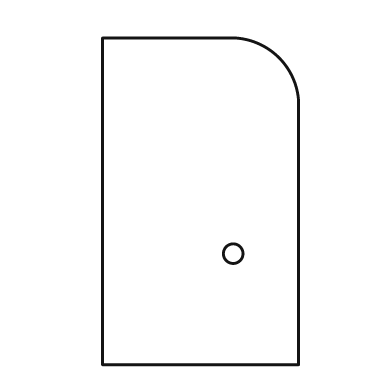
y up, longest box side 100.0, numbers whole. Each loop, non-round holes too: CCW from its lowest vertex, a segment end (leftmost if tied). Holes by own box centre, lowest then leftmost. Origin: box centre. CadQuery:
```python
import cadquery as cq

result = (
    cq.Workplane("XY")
    .moveTo(-30.0, -50.0)
    .lineTo(30.0, -50.0)
    .lineTo(30.0, 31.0)
    .threePointArc((24.0, 44.0), (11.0, 50.0))
    .lineTo(-30.0, 50.0)
    .close()
    .moveTo(10.0, -16.0)
    .circle(3.0)
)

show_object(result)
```